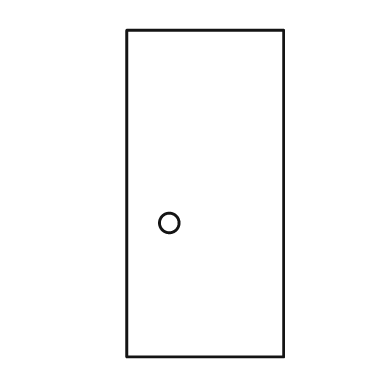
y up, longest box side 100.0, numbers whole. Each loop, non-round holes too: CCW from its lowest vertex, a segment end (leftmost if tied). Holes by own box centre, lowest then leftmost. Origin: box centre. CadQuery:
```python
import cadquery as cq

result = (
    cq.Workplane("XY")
    .moveTo(-24.0, -50.0)
    .lineTo(24.0, -50.0)
    .lineTo(24.0, 50.0)
    .lineTo(-24.0, 50.0)
    .close()
    .moveTo(-11.0, -9.0)
    .circle(3.0)
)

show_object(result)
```